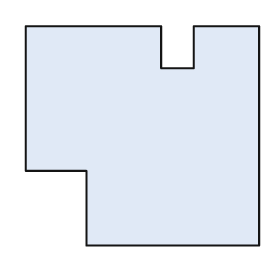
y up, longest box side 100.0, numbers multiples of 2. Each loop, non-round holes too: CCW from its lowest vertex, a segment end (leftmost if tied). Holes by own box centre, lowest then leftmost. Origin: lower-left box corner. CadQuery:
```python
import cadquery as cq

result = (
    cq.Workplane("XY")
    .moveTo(26.0, 0.0)
    .lineTo(100.0, 0.0)
    .lineTo(100.0, 94.0)
    .lineTo(72.0, 94.0)
    .lineTo(72.0, 76.0)
    .lineTo(58.0, 76.0)
    .lineTo(58.0, 94.0)
    .lineTo(0.0, 94.0)
    .lineTo(0.0, 32.0)
    .lineTo(26.0, 32.0)
    .close()
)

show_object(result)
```